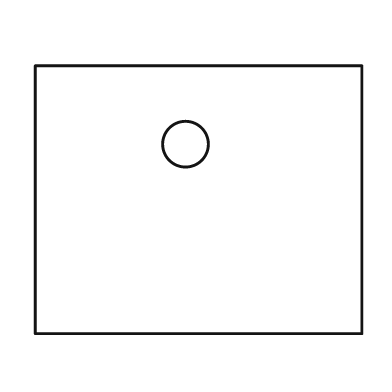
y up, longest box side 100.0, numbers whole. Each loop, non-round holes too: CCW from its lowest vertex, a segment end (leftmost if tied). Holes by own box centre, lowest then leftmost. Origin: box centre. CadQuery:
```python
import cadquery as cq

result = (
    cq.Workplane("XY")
    .moveTo(-50.0, -41.0)
    .lineTo(50.0, -41.0)
    .lineTo(50.0, 41.0)
    .lineTo(-50.0, 41.0)
    .close()
    .moveTo(-4.0, 17.0)
    .circle(7.0)
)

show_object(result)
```